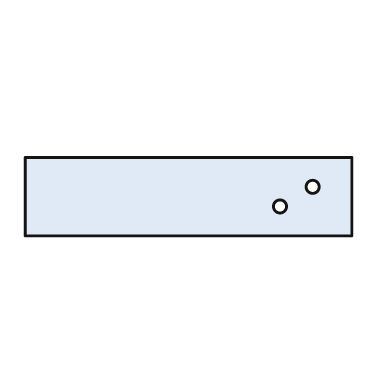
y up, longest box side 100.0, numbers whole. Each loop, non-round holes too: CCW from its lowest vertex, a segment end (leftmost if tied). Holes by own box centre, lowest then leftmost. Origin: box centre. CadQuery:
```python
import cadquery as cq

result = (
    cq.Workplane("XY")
    .moveTo(-50.0, -12.0)
    .lineTo(50.0, -12.0)
    .lineTo(50.0, 12.0)
    .lineTo(-50.0, 12.0)
    .close()
    .moveTo(28.0, -3.0)
    .circle(2.0)
    .moveTo(38.0, 3.0)
    .circle(2.0)
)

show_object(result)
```